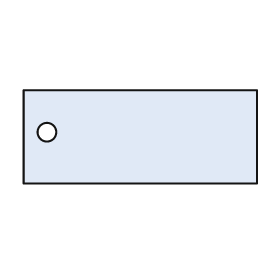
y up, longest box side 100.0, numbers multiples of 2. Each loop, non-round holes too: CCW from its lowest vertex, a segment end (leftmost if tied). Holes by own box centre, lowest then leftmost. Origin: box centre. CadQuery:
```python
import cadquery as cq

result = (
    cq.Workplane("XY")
    .moveTo(-50.0, -20.0)
    .lineTo(50.0, -20.0)
    .lineTo(50.0, 20.0)
    .lineTo(-50.0, 20.0)
    .close()
    .moveTo(-40.0, 2.0)
    .circle(4.0)
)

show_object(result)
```